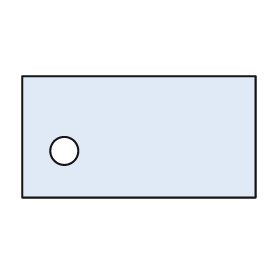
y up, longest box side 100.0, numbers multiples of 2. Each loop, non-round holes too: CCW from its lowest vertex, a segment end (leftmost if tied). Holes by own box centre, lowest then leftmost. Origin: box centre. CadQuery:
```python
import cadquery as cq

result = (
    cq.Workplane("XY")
    .moveTo(-50.0, -26.0)
    .lineTo(50.0, -26.0)
    .lineTo(50.0, 26.0)
    .lineTo(-50.0, 26.0)
    .close()
    .moveTo(-32.0, -6.0)
    .circle(6.0)
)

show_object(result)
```